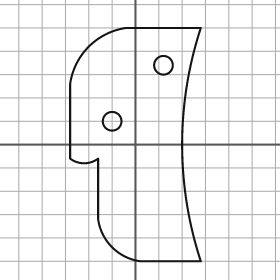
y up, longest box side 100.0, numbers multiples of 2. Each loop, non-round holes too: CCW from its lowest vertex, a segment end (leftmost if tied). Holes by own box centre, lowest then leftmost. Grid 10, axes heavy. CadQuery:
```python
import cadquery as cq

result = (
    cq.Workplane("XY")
    .moveTo(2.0, -50.0)
    .lineTo(28.0, -50.0)
    .threePointArc((20.0, 0.0), (28.0, 50.0))
    .lineTo(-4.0, 50.0)
    .threePointArc((-20.0, 42.0), (-28.0, 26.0))
    .lineTo(-28.0, -6.0)
    .threePointArc((-22.0, -8.0), (-16.0, -6.0))
    .lineTo(-16.0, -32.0)
    .threePointArc((-10.0, -44.0), (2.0, -50.0))
    .close()
    .moveTo(-10.0, 10.0)
    .circle(4.0)
    .moveTo(12.0, 34.0)
    .circle(4.0)
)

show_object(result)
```